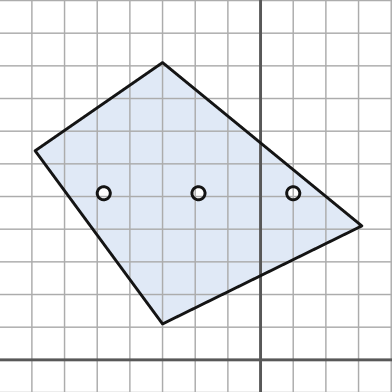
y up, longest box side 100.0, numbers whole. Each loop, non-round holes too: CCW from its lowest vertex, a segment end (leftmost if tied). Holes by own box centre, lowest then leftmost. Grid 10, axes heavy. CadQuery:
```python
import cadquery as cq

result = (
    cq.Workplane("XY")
    .moveTo(-30.0, 11.0)
    .lineTo(31.0, 41.0)
    .lineTo(-30.0, 91.0)
    .lineTo(-69.0, 64.0)
    .close()
    .moveTo(-48.0, 51.0)
    .circle(2.0)
    .moveTo(-19.0, 51.0)
    .circle(2.0)
    .moveTo(10.0, 51.0)
    .circle(2.0)
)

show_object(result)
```